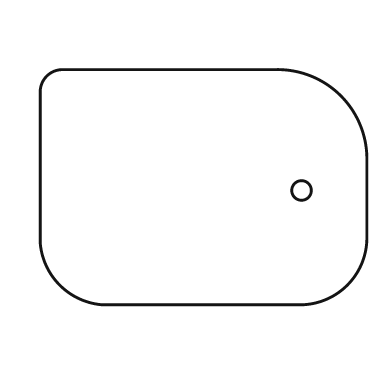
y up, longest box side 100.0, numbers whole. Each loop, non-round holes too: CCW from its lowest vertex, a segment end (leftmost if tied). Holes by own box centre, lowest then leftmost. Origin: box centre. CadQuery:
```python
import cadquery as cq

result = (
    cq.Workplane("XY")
    .moveTo(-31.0, -36.0)
    .lineTo(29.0, -36.0)
    .threePointArc((44.0, -30.0), (50.0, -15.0))
    .lineTo(50.0, 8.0)
    .threePointArc((42.0, 28.0), (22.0, 36.0))
    .lineTo(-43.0, 36.0)
    .threePointArc((-48.0, 34.0), (-50.0, 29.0))
    .lineTo(-50.0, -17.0)
    .threePointArc((-44.0, -30.0), (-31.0, -36.0))
    .close()
    .moveTo(30.0, -1.0)
    .circle(3.0)
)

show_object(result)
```